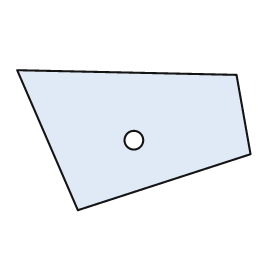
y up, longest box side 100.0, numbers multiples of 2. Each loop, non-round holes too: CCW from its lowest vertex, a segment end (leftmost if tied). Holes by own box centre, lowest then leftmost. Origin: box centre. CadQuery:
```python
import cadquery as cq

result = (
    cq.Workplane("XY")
    .moveTo(-24.0, -30.0)
    .lineTo(50.0, -6.0)
    .lineTo(44.0, 28.0)
    .lineTo(-50.0, 30.0)
    .close()
    .moveTo(0.0, 0.0)
    .circle(4.0)
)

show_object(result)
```